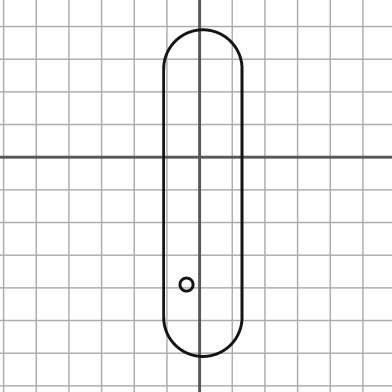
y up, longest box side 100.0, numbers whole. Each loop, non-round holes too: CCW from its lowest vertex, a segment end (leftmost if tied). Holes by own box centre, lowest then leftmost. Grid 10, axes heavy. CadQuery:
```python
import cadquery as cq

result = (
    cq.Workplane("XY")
    .moveTo(-11.0, -49.0)
    .threePointArc((1.0, -61.0), (13.0, -49.0))
    .lineTo(13.0, 27.0)
    .threePointArc((1.0, 39.0), (-11.0, 27.0))
    .close()
    .moveTo(-4.0, -39.0)
    .circle(2.0)
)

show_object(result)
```